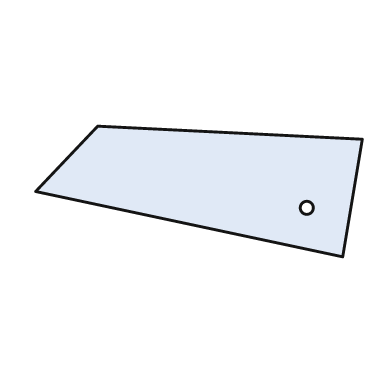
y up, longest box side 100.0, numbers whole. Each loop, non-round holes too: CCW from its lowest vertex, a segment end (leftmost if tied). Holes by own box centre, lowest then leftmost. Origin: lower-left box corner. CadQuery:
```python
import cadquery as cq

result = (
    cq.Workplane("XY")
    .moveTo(94.0, 0.0)
    .lineTo(100.0, 36.0)
    .lineTo(19.0, 40.0)
    .lineTo(0.0, 20.0)
    .close()
    .moveTo(83.0, 15.0)
    .circle(2.0)
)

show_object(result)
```